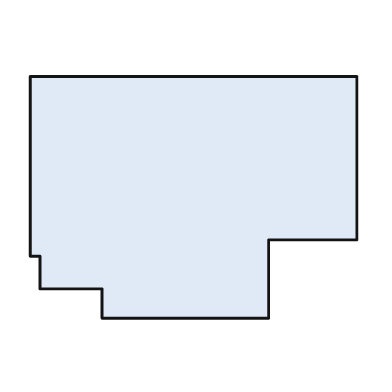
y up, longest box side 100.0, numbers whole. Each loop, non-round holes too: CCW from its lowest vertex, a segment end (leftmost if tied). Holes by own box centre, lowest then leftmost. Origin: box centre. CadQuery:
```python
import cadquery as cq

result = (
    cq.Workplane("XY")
    .moveTo(-28.0, -37.0)
    .lineTo(23.0, -37.0)
    .lineTo(23.0, -13.0)
    .lineTo(50.0, -13.0)
    .lineTo(50.0, 37.0)
    .lineTo(-50.0, 37.0)
    .lineTo(-50.0, -18.0)
    .lineTo(-47.0, -18.0)
    .lineTo(-47.0, -28.0)
    .lineTo(-28.0, -28.0)
    .close()
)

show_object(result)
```